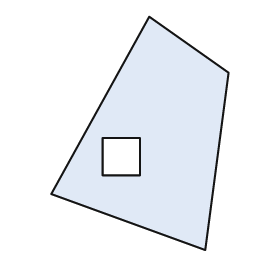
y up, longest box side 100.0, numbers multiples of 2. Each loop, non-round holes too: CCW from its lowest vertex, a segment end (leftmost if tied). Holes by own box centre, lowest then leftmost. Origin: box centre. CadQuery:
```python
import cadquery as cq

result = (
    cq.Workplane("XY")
    .moveTo(28.0, -50.0)
    .lineTo(38.0, 26.0)
    .lineTo(4.0, 50.0)
    .lineTo(-38.0, -26.0)
    .close()
    .moveTo(-16.0, -18.0)
    .lineTo(0.0, -18.0)
    .lineTo(0.0, -2.0)
    .lineTo(-16.0, -2.0)
    .close()
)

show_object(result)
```